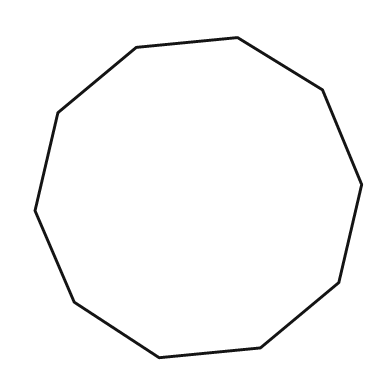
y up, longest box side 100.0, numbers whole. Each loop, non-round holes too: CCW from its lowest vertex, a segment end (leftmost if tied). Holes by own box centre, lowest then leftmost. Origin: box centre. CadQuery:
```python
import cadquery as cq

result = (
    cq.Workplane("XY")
    .moveTo(-12.0, -49.0)
    .lineTo(19.0, -46.0)
    .lineTo(43.0, -26.0)
    .lineTo(50.0, 4.0)
    .lineTo(38.0, 33.0)
    .lineTo(12.0, 49.0)
    .lineTo(-19.0, 46.0)
    .lineTo(-43.0, 26.0)
    .lineTo(-50.0, -4.0)
    .lineTo(-38.0, -32.0)
    .close()
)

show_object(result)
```